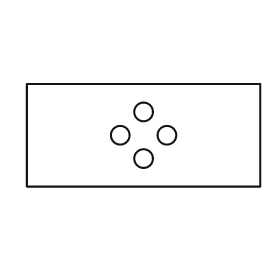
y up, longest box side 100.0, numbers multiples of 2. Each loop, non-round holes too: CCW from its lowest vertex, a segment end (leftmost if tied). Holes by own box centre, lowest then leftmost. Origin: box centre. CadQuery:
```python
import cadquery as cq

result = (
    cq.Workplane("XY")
    .moveTo(-50.0, -22.0)
    .lineTo(50.0, -22.0)
    .lineTo(50.0, 22.0)
    .lineTo(-50.0, 22.0)
    .close()
    .moveTo(0.0, -10.0)
    .circle(4.0)
    .moveTo(-10.0, 0.0)
    .circle(4.0)
    .moveTo(10.0, 0.0)
    .circle(4.0)
    .moveTo(0.0, 10.0)
    .circle(4.0)
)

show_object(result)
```